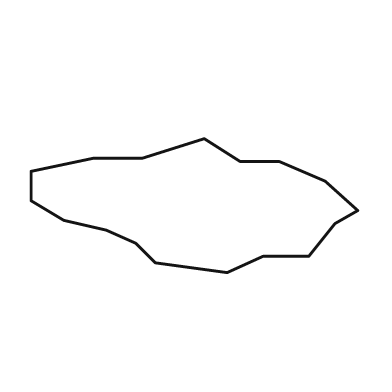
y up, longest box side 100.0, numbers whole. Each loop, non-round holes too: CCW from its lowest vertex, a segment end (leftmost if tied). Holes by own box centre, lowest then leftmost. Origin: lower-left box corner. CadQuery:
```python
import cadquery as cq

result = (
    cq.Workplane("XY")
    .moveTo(60.0, 0.0)
    .lineTo(71.0, 5.0)
    .lineTo(85.0, 5.0)
    .lineTo(93.0, 15.0)
    .lineTo(100.0, 19.0)
    .lineTo(90.0, 28.0)
    .lineTo(76.0, 34.0)
    .lineTo(64.0, 34.0)
    .lineTo(53.0, 41.0)
    .lineTo(34.0, 35.0)
    .lineTo(19.0, 35.0)
    .lineTo(0.0, 31.0)
    .lineTo(0.0, 22.0)
    .lineTo(10.0, 16.0)
    .lineTo(23.0, 13.0)
    .lineTo(32.0, 9.0)
    .lineTo(38.0, 3.0)
    .close()
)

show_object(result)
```